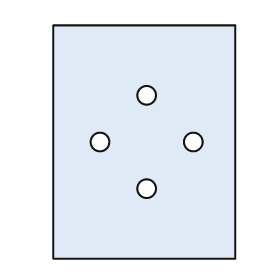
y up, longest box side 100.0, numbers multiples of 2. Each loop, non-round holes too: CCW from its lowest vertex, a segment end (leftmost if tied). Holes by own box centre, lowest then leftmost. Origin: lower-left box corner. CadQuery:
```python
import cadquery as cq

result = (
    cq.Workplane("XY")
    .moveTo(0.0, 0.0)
    .lineTo(78.0, 0.0)
    .lineTo(78.0, 100.0)
    .lineTo(0.0, 100.0)
    .close()
    .moveTo(40.0, 30.0)
    .circle(4.0)
    .moveTo(20.0, 50.0)
    .circle(4.0)
    .moveTo(60.0, 50.0)
    .circle(4.0)
    .moveTo(40.0, 70.0)
    .circle(4.0)
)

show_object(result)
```